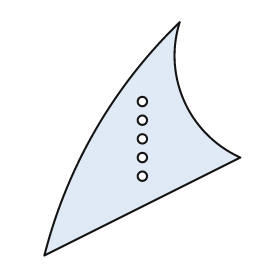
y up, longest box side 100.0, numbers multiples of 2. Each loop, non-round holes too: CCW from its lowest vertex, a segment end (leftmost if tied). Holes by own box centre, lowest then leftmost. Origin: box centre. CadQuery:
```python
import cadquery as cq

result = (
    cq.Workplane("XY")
    .moveTo(-42.0, -50.0)
    .lineTo(42.0, -8.0)
    .threePointArc((18.0, 16.0), (16.0, 50.0))
    .threePointArc((-20.0, 4.0), (-42.0, -50.0))
    .close()
    .moveTo(0.0, -16.0)
    .circle(2.0)
    .moveTo(0.0, -8.0)
    .circle(2.0)
    .moveTo(0.0, 0.0)
    .circle(2.0)
    .moveTo(0.0, 8.0)
    .circle(2.0)
    .moveTo(0.0, 16.0)
    .circle(2.0)
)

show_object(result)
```